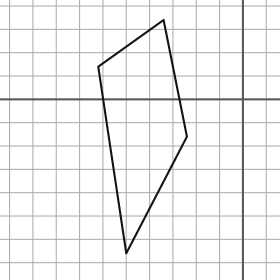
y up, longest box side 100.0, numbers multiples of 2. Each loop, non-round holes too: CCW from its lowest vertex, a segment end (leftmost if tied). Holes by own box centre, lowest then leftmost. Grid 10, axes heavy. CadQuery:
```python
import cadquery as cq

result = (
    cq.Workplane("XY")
    .moveTo(-50.0, -66.0)
    .lineTo(-24.0, -16.0)
    .lineTo(-34.0, 34.0)
    .lineTo(-62.0, 14.0)
    .close()
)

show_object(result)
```